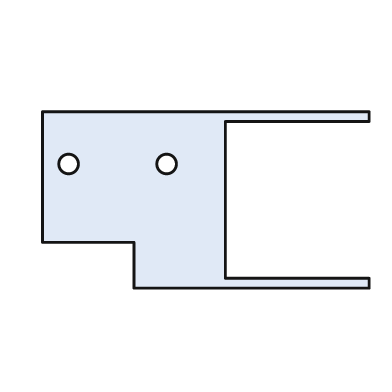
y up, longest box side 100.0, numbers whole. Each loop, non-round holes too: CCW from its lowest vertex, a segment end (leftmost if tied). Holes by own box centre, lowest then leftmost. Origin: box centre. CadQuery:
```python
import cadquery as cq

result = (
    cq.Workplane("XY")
    .moveTo(-22.0, -27.0)
    .lineTo(50.0, -27.0)
    .lineTo(50.0, -24.0)
    .lineTo(6.0, -24.0)
    .lineTo(6.0, 24.0)
    .lineTo(50.0, 24.0)
    .lineTo(50.0, 27.0)
    .lineTo(-50.0, 27.0)
    .lineTo(-50.0, -13.0)
    .lineTo(-22.0, -13.0)
    .close()
    .moveTo(-42.0, 11.0)
    .circle(3.0)
    .moveTo(-12.0, 11.0)
    .circle(3.0)
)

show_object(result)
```